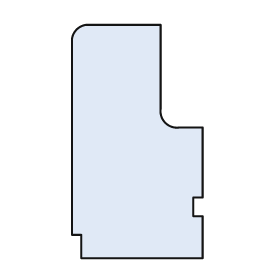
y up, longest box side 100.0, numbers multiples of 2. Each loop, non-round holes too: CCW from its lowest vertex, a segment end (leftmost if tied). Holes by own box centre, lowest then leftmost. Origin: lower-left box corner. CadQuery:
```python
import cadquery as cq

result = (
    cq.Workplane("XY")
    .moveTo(4.0, 0.0)
    .lineTo(56.0, 0.0)
    .lineTo(56.0, 18.0)
    .lineTo(52.0, 18.0)
    .lineTo(52.0, 26.0)
    .lineTo(56.0, 26.0)
    .lineTo(56.0, 56.0)
    .lineTo(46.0, 56.0)
    .threePointArc((40.0, 58.0), (38.0, 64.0))
    .lineTo(38.0, 100.0)
    .lineTo(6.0, 100.0)
    .threePointArc((2.0, 98.0), (0.0, 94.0))
    .lineTo(0.0, 10.0)
    .lineTo(4.0, 10.0)
    .close()
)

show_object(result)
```